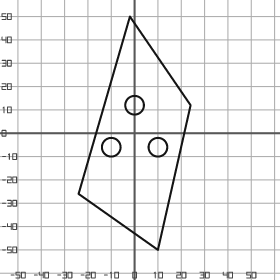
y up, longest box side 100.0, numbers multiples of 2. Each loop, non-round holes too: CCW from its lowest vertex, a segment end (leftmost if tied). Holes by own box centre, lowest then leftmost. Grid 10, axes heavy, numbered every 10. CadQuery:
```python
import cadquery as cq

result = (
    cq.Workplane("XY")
    .moveTo(10.0, -50.0)
    .lineTo(24.0, 12.0)
    .lineTo(-2.0, 50.0)
    .lineTo(-24.0, -26.0)
    .close()
    .moveTo(-10.0, -6.0)
    .circle(4.0)
    .moveTo(10.0, -6.0)
    .circle(4.0)
    .moveTo(0.0, 12.0)
    .circle(4.0)
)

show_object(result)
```